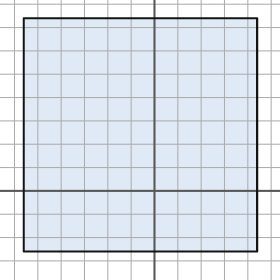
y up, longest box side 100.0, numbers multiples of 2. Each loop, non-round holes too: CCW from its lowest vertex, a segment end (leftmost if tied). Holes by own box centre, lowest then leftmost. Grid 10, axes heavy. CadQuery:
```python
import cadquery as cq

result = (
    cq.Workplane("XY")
    .moveTo(-56.0, -26.0)
    .lineTo(44.0, -26.0)
    .lineTo(44.0, 74.0)
    .lineTo(-56.0, 74.0)
    .close()
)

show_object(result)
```